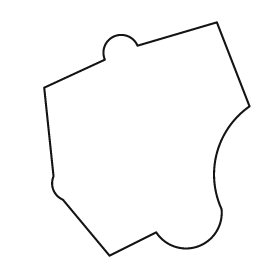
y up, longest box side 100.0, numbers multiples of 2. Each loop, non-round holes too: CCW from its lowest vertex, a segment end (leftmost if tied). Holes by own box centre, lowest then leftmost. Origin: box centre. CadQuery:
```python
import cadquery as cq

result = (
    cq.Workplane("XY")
    .moveTo(-16.0, -50.0)
    .lineTo(4.0, -40.0)
    .threePointArc((22.0, -46.0), (32.0, -30.0))
    .threePointArc((30.0, -6.0), (44.0, 14.0))
    .lineTo(30.0, 50.0)
    .lineTo(-4.0, 40.0)
    .threePointArc((-14.0, 44.0), (-18.0, 34.0))
    .lineTo(-44.0, 22.0)
    .lineTo(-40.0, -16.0)
    .threePointArc((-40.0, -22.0), (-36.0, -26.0))
    .close()
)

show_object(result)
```